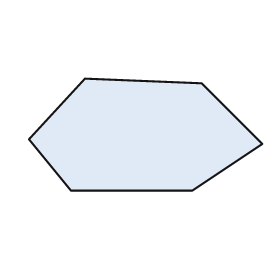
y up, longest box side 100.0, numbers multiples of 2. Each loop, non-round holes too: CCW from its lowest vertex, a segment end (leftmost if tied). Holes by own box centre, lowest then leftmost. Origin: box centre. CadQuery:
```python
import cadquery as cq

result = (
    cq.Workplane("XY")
    .moveTo(-32.0, -24.0)
    .lineTo(20.0, -24.0)
    .lineTo(50.0, -4.0)
    .lineTo(24.0, 22.0)
    .lineTo(-26.0, 24.0)
    .lineTo(-50.0, -2.0)
    .close()
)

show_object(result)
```